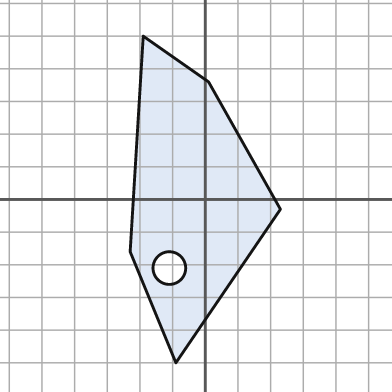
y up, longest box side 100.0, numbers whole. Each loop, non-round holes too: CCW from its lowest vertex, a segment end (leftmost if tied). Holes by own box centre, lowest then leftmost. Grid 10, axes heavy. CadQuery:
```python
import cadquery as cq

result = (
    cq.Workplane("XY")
    .moveTo(-9.0, -50.0)
    .lineTo(23.0, -3.0)
    .lineTo(1.0, 36.0)
    .lineTo(-19.0, 50.0)
    .lineTo(-23.0, -16.0)
    .close()
    .moveTo(-11.0, -21.0)
    .circle(5.0)
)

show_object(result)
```